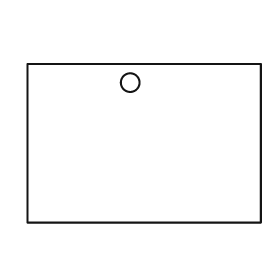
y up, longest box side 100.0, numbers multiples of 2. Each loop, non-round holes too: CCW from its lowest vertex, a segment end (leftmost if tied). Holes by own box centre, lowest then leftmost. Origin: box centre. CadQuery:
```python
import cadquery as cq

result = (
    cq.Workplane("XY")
    .moveTo(-50.0, -34.0)
    .lineTo(50.0, -34.0)
    .lineTo(50.0, 34.0)
    .lineTo(-50.0, 34.0)
    .close()
    .moveTo(-6.0, 26.0)
    .circle(4.0)
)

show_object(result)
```